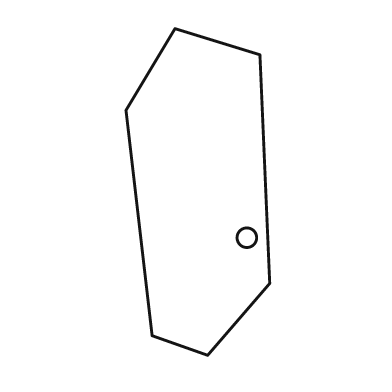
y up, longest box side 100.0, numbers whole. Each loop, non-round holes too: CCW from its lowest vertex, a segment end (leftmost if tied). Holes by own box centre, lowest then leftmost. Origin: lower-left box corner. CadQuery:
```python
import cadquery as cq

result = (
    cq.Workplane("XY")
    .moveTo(25.0, 0.0)
    .lineTo(44.0, 22.0)
    .lineTo(41.0, 92.0)
    .lineTo(15.0, 100.0)
    .lineTo(0.0, 75.0)
    .lineTo(8.0, 6.0)
    .close()
    .moveTo(37.0, 36.0)
    .circle(3.0)
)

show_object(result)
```